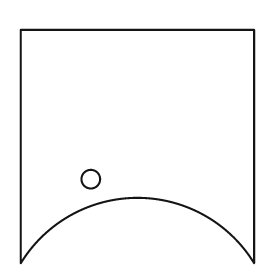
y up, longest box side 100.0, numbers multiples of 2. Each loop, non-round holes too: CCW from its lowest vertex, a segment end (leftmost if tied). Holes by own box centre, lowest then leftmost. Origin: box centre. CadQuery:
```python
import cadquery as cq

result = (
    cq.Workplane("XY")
    .moveTo(-50.0, -50.0)
    .threePointArc((0.0, -22.0), (50.0, -50.0))
    .lineTo(50.0, 50.0)
    .lineTo(-50.0, 50.0)
    .close()
    .moveTo(-20.0, -14.0)
    .circle(4.0)
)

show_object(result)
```